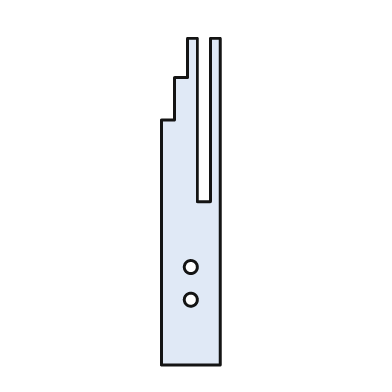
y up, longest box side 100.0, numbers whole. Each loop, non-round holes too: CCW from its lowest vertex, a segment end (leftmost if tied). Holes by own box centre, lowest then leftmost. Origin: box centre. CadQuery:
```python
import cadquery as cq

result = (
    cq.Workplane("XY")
    .moveTo(-9.0, -50.0)
    .lineTo(9.0, -50.0)
    .lineTo(9.0, 50.0)
    .lineTo(6.0, 50.0)
    .lineTo(6.0, 0.0)
    .lineTo(2.0, 0.0)
    .lineTo(2.0, 50.0)
    .lineTo(-1.0, 50.0)
    .lineTo(-1.0, 38.0)
    .lineTo(-5.0, 38.0)
    .lineTo(-5.0, 25.0)
    .lineTo(-9.0, 25.0)
    .close()
    .moveTo(0.0, -30.0)
    .circle(2.0)
    .moveTo(0.0, -20.0)
    .circle(2.0)
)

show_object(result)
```